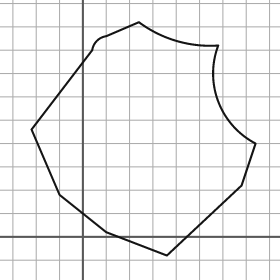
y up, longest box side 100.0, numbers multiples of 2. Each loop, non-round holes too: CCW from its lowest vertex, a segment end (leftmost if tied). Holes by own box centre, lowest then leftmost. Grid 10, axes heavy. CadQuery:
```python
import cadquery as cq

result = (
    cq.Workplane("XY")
    .moveTo(36.0, -8.0)
    .lineTo(68.0, 22.0)
    .lineTo(74.0, 40.0)
    .threePointArc((58.0, 58.0), (58.0, 82.0))
    .threePointArc((40.0, 84.0), (24.0, 92.0))
    .lineTo(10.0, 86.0)
    .threePointArc((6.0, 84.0), (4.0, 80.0))
    .lineTo(-22.0, 46.0)
    .lineTo(-10.0, 18.0)
    .lineTo(10.0, 2.0)
    .close()
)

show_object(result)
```